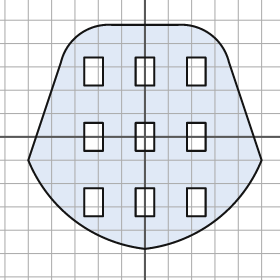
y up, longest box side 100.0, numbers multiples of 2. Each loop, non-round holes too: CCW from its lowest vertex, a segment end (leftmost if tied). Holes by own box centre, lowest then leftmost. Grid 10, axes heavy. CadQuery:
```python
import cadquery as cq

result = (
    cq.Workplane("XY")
    .moveTo(0.0, -48.0)
    .threePointArc((30.0, -36.0), (50.0, -10.0))
    .lineTo(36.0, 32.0)
    .threePointArc((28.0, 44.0), (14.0, 48.0))
    .lineTo(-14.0, 48.0)
    .threePointArc((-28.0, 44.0), (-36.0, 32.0))
    .lineTo(-50.0, -10.0)
    .threePointArc((-30.0, -36.0), (0.0, -48.0))
    .close()
    .moveTo(-26.0, -34.0)
    .lineTo(-18.0, -34.0)
    .lineTo(-18.0, -22.0)
    .lineTo(-26.0, -22.0)
    .close()
    .moveTo(-4.0, -34.0)
    .lineTo(4.0, -34.0)
    .lineTo(4.0, -22.0)
    .lineTo(-4.0, -22.0)
    .close()
    .moveTo(18.0, -34.0)
    .lineTo(26.0, -34.0)
    .lineTo(26.0, -22.0)
    .lineTo(18.0, -22.0)
    .close()
    .moveTo(-26.0, -6.0)
    .lineTo(-18.0, -6.0)
    .lineTo(-18.0, 6.0)
    .lineTo(-26.0, 6.0)
    .close()
    .moveTo(-4.0, -6.0)
    .lineTo(4.0, -6.0)
    .lineTo(4.0, 6.0)
    .lineTo(-4.0, 6.0)
    .close()
    .moveTo(18.0, -6.0)
    .lineTo(26.0, -6.0)
    .lineTo(26.0, 6.0)
    .lineTo(18.0, 6.0)
    .close()
    .moveTo(-26.0, 22.0)
    .lineTo(-18.0, 22.0)
    .lineTo(-18.0, 34.0)
    .lineTo(-26.0, 34.0)
    .close()
    .moveTo(-4.0, 22.0)
    .lineTo(4.0, 22.0)
    .lineTo(4.0, 34.0)
    .lineTo(-4.0, 34.0)
    .close()
    .moveTo(18.0, 22.0)
    .lineTo(26.0, 22.0)
    .lineTo(26.0, 34.0)
    .lineTo(18.0, 34.0)
    .close()
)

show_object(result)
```